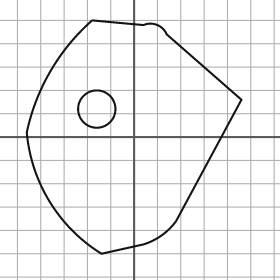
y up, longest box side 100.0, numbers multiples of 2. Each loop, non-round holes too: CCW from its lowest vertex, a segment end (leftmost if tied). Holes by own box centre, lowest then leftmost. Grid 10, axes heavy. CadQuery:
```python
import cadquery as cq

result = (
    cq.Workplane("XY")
    .moveTo(-14.0, -50.0)
    .lineTo(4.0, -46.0)
    .threePointArc((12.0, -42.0), (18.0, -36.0))
    .lineTo(46.0, 16.0)
    .lineTo(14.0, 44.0)
    .threePointArc((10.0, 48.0), (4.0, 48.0))
    .lineTo(-18.0, 50.0)
    .threePointArc((-36.0, 28.0), (-46.0, 2.0))
    .threePointArc((-36.0, -28.0), (-14.0, -50.0))
    .close()
    .moveTo(-16.0, 12.0)
    .circle(8.0)
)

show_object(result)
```